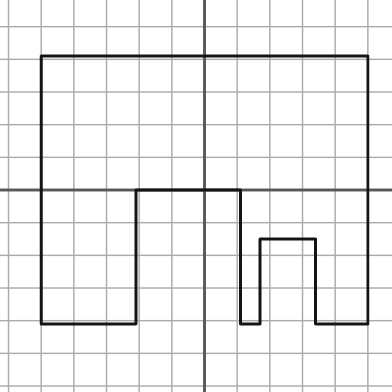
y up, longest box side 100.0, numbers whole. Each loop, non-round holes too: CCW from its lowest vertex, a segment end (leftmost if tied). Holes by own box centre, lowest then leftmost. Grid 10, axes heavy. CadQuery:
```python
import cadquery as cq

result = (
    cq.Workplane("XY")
    .moveTo(-50.0, -41.0)
    .lineTo(-21.0, -41.0)
    .lineTo(-21.0, 0.0)
    .lineTo(11.0, 0.0)
    .lineTo(11.0, -41.0)
    .lineTo(17.0, -41.0)
    .lineTo(17.0, -15.0)
    .lineTo(34.0, -15.0)
    .lineTo(34.0, -41.0)
    .lineTo(50.0, -41.0)
    .lineTo(50.0, 41.0)
    .lineTo(-50.0, 41.0)
    .close()
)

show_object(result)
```